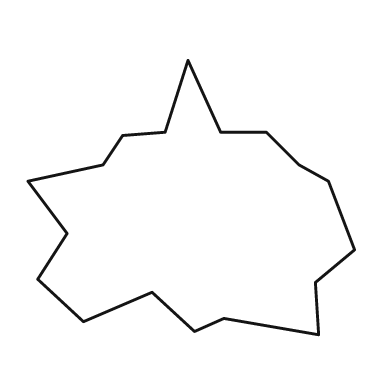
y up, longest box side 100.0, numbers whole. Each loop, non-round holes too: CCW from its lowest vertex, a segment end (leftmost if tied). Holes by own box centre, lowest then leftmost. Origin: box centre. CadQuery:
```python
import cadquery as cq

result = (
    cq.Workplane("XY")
    .moveTo(39.0, -42.0)
    .lineTo(38.0, -26.0)
    .lineTo(50.0, -16.0)
    .lineTo(42.0, 5.0)
    .lineTo(33.0, 10.0)
    .lineTo(23.0, 20.0)
    .lineTo(9.0, 20.0)
    .lineTo(-1.0, 42.0)
    .lineTo(-8.0, 20.0)
    .lineTo(-21.0, 19.0)
    .lineTo(-27.0, 10.0)
    .lineTo(-50.0, 5.0)
    .lineTo(-38.0, -11.0)
    .lineTo(-47.0, -25.0)
    .lineTo(-33.0, -38.0)
    .lineTo(-12.0, -29.0)
    .lineTo(1.0, -41.0)
    .lineTo(10.0, -37.0)
    .close()
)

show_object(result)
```